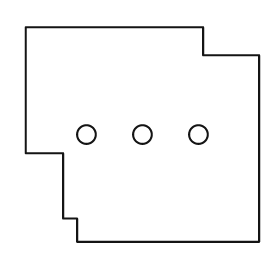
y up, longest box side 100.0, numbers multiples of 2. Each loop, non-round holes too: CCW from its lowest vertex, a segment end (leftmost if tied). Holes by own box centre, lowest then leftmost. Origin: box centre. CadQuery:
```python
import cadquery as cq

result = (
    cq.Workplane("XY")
    .moveTo(-28.0, -46.0)
    .lineTo(50.0, -46.0)
    .lineTo(50.0, 34.0)
    .lineTo(26.0, 34.0)
    .lineTo(26.0, 46.0)
    .lineTo(-50.0, 46.0)
    .lineTo(-50.0, -8.0)
    .lineTo(-34.0, -8.0)
    .lineTo(-34.0, -36.0)
    .lineTo(-28.0, -36.0)
    .close()
    .moveTo(-24.0, 0.0)
    .circle(4.0)
    .moveTo(0.0, 0.0)
    .circle(4.0)
    .moveTo(24.0, 0.0)
    .circle(4.0)
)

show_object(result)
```